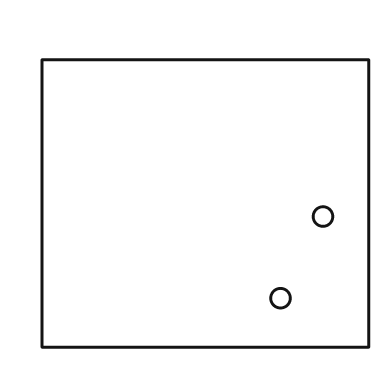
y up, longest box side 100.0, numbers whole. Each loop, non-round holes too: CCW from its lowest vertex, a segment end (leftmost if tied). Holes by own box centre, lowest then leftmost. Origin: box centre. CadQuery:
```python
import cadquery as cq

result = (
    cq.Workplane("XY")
    .moveTo(-50.0, -44.0)
    .lineTo(50.0, -44.0)
    .lineTo(50.0, 44.0)
    .lineTo(-50.0, 44.0)
    .close()
    .moveTo(23.0, -29.0)
    .circle(3.0)
    .moveTo(36.0, -4.0)
    .circle(3.0)
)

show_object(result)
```